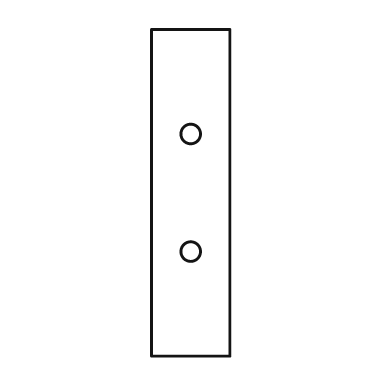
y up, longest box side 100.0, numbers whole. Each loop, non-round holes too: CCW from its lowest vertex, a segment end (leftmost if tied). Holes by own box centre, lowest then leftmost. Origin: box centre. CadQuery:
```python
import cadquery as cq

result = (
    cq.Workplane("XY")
    .moveTo(-12.0, -50.0)
    .lineTo(12.0, -50.0)
    .lineTo(12.0, 50.0)
    .lineTo(-12.0, 50.0)
    .close()
    .moveTo(0.0, -18.0)
    .circle(3.0)
    .moveTo(0.0, 18.0)
    .circle(3.0)
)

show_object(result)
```